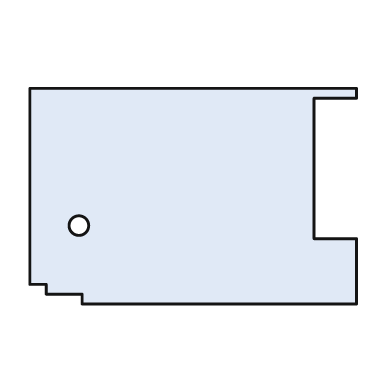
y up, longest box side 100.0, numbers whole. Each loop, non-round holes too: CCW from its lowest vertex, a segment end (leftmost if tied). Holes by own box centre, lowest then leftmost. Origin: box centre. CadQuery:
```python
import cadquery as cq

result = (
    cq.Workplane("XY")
    .moveTo(-34.0, -33.0)
    .lineTo(50.0, -33.0)
    .lineTo(50.0, -13.0)
    .lineTo(37.0, -13.0)
    .lineTo(37.0, 30.0)
    .lineTo(50.0, 30.0)
    .lineTo(50.0, 33.0)
    .lineTo(-50.0, 33.0)
    .lineTo(-50.0, -27.0)
    .lineTo(-45.0, -27.0)
    .lineTo(-45.0, -30.0)
    .lineTo(-34.0, -30.0)
    .close()
    .moveTo(-35.0, -9.0)
    .circle(3.0)
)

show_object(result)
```